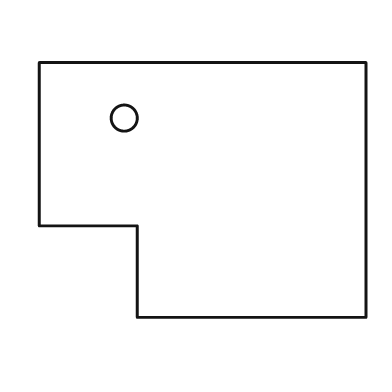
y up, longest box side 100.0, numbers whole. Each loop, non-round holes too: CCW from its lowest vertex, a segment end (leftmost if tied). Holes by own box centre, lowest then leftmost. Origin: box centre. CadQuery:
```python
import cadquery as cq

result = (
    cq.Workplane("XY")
    .moveTo(-20.0, -39.0)
    .lineTo(50.0, -39.0)
    .lineTo(50.0, 39.0)
    .lineTo(-50.0, 39.0)
    .lineTo(-50.0, -11.0)
    .lineTo(-20.0, -11.0)
    .close()
    .moveTo(-24.0, 22.0)
    .circle(4.0)
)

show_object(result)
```